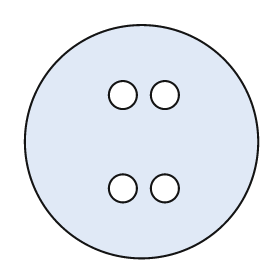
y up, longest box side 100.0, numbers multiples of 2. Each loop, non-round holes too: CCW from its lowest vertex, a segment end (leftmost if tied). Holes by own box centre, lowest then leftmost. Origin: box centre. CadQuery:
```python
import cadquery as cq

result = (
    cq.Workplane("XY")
    .moveTo(0.0, 0.0)
    .circle(50.0)
    .moveTo(-8.0, -20.0)
    .circle(6.0)
    .moveTo(10.0, -20.0)
    .circle(6.0)
    .moveTo(-8.0, 20.0)
    .circle(6.0)
    .moveTo(10.0, 20.0)
    .circle(6.0)
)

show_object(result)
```